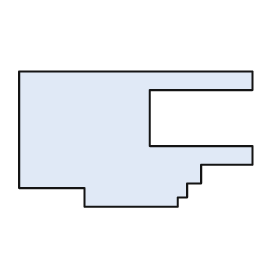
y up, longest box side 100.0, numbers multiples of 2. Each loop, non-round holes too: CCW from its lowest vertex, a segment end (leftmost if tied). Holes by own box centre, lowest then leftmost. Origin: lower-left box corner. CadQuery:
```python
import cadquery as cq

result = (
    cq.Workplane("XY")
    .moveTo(28.0, 0.0)
    .lineTo(68.0, 0.0)
    .lineTo(68.0, 4.0)
    .lineTo(72.0, 4.0)
    .lineTo(72.0, 10.0)
    .lineTo(78.0, 10.0)
    .lineTo(78.0, 18.0)
    .lineTo(100.0, 18.0)
    .lineTo(100.0, 26.0)
    .lineTo(56.0, 26.0)
    .lineTo(56.0, 50.0)
    .lineTo(100.0, 50.0)
    .lineTo(100.0, 58.0)
    .lineTo(0.0, 58.0)
    .lineTo(0.0, 8.0)
    .lineTo(28.0, 8.0)
    .close()
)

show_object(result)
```